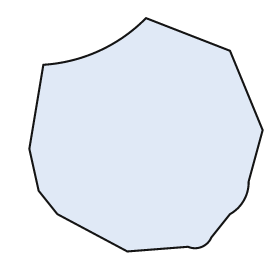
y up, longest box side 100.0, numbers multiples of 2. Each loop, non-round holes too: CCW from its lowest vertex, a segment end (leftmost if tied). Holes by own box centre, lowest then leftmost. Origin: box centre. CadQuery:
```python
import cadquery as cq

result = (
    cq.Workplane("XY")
    .moveTo(-8.0, -50.0)
    .lineTo(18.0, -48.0)
    .threePointArc((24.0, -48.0), (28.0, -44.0))
    .lineTo(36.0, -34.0)
    .threePointArc((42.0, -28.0), (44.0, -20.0))
    .lineTo(50.0, 2.0)
    .lineTo(36.0, 36.0)
    .lineTo(0.0, 50.0)
    .threePointArc((-20.0, 36.0), (-44.0, 30.0))
    .lineTo(-50.0, -6.0)
    .lineTo(-46.0, -24.0)
    .lineTo(-38.0, -34.0)
    .close()
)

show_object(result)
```